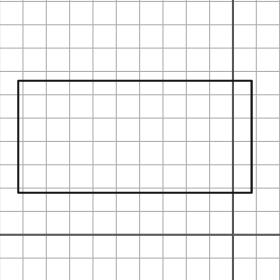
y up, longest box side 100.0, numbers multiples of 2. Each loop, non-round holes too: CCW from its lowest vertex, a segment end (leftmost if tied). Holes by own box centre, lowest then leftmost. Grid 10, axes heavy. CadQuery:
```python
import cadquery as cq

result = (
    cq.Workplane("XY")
    .moveTo(-92.0, 18.0)
    .lineTo(8.0, 18.0)
    .lineTo(8.0, 66.0)
    .lineTo(-92.0, 66.0)
    .close()
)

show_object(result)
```